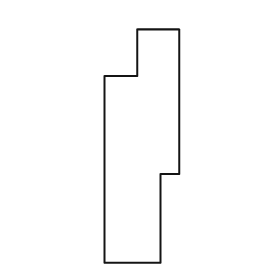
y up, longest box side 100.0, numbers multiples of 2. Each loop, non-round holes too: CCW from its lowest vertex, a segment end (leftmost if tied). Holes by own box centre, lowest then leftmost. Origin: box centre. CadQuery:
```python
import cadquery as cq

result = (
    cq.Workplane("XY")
    .moveTo(-16.0, -50.0)
    .lineTo(8.0, -50.0)
    .lineTo(8.0, -12.0)
    .lineTo(16.0, -12.0)
    .lineTo(16.0, 50.0)
    .lineTo(-2.0, 50.0)
    .lineTo(-2.0, 30.0)
    .lineTo(-16.0, 30.0)
    .close()
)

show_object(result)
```